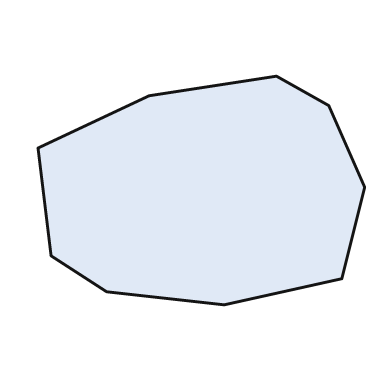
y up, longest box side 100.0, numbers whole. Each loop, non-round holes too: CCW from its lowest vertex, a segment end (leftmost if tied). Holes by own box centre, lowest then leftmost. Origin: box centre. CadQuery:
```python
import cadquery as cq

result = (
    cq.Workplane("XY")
    .moveTo(7.0, -35.0)
    .lineTo(43.0, -27.0)
    .lineTo(50.0, 1.0)
    .lineTo(39.0, 26.0)
    .lineTo(23.0, 35.0)
    .lineTo(-16.0, 29.0)
    .lineTo(-50.0, 13.0)
    .lineTo(-46.0, -20.0)
    .lineTo(-29.0, -31.0)
    .close()
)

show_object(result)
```